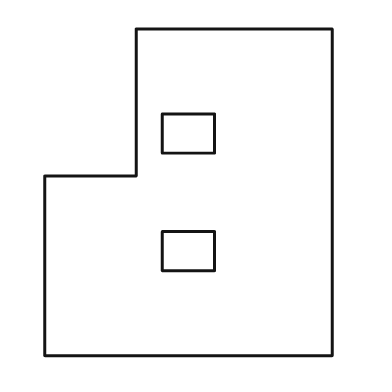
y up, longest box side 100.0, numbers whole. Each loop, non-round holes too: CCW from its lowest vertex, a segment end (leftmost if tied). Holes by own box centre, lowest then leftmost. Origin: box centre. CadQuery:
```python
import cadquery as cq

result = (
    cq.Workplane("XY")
    .moveTo(-44.0, -50.0)
    .lineTo(44.0, -50.0)
    .lineTo(44.0, 50.0)
    .lineTo(-16.0, 50.0)
    .lineTo(-16.0, 5.0)
    .lineTo(-44.0, 5.0)
    .close()
    .moveTo(-8.0, -24.0)
    .lineTo(8.0, -24.0)
    .lineTo(8.0, -12.0)
    .lineTo(-8.0, -12.0)
    .close()
    .moveTo(-8.0, 12.0)
    .lineTo(8.0, 12.0)
    .lineTo(8.0, 24.0)
    .lineTo(-8.0, 24.0)
    .close()
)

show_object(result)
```